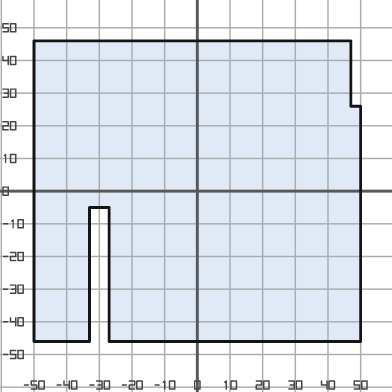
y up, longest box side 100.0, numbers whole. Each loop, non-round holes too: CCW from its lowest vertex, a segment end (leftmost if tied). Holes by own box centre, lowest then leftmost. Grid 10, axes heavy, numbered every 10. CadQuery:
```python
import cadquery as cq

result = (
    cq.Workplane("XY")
    .moveTo(-50.0, -46.0)
    .lineTo(-33.0, -46.0)
    .lineTo(-33.0, -5.0)
    .lineTo(-27.0, -5.0)
    .lineTo(-27.0, -46.0)
    .lineTo(50.0, -46.0)
    .lineTo(50.0, 26.0)
    .lineTo(47.0, 26.0)
    .lineTo(47.0, 46.0)
    .lineTo(-50.0, 46.0)
    .close()
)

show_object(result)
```